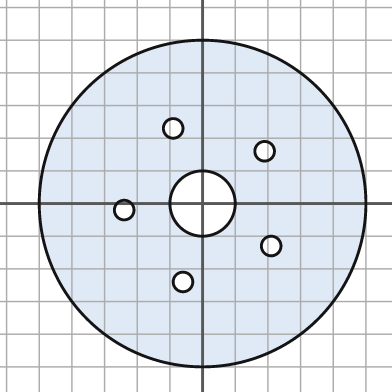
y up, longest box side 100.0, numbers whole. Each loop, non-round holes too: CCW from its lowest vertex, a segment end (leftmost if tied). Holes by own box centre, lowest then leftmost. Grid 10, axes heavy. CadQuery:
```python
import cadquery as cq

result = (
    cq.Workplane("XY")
    .moveTo(0.0, 0.0)
    .circle(50.0)
    .moveTo(-6.0, -24.0)
    .circle(3.0)
    .moveTo(21.0, -13.0)
    .circle(3.0)
    .moveTo(-24.0, -2.0)
    .circle(3.0)
    .moveTo(0.0, 0.0)
    .circle(10.0)
    .moveTo(19.0, 16.0)
    .circle(3.0)
    .moveTo(-9.0, 23.0)
    .circle(3.0)
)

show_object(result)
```